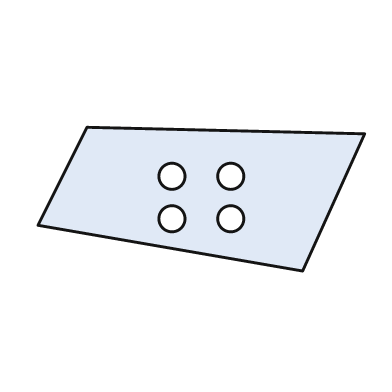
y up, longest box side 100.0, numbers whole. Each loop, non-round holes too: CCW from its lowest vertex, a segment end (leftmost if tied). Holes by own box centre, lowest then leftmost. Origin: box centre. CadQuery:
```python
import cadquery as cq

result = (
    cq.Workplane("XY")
    .moveTo(31.0, -22.0)
    .lineTo(50.0, 20.0)
    .lineTo(-35.0, 22.0)
    .lineTo(-50.0, -8.0)
    .close()
    .moveTo(-9.0, -6.0)
    .circle(4.0)
    .moveTo(9.0, -6.0)
    .circle(4.0)
    .moveTo(-9.0, 7.0)
    .circle(4.0)
    .moveTo(9.0, 7.0)
    .circle(4.0)
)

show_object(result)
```